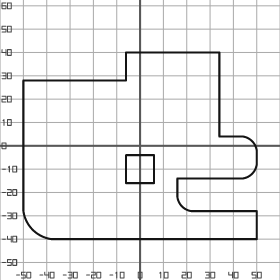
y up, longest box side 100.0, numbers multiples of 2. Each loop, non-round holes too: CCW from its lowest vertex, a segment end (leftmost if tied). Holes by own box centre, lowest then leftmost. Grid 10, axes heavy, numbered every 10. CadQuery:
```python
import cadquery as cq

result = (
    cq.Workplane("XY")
    .moveTo(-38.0, -40.0)
    .lineTo(50.0, -40.0)
    .lineTo(50.0, -28.0)
    .lineTo(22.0, -28.0)
    .threePointArc((18.0, -26.0), (16.0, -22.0))
    .lineTo(16.0, -14.0)
    .lineTo(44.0, -14.0)
    .threePointArc((48.0, -12.0), (50.0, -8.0))
    .lineTo(50.0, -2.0)
    .threePointArc((48.0, 2.0), (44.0, 4.0))
    .lineTo(34.0, 4.0)
    .lineTo(34.0, 40.0)
    .lineTo(-6.0, 40.0)
    .lineTo(-6.0, 28.0)
    .lineTo(-50.0, 28.0)
    .lineTo(-50.0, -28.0)
    .threePointArc((-46.0, -36.0), (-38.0, -40.0))
    .close()
    .moveTo(-6.0, -16.0)
    .lineTo(6.0, -16.0)
    .lineTo(6.0, -4.0)
    .lineTo(-6.0, -4.0)
    .close()
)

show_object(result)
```